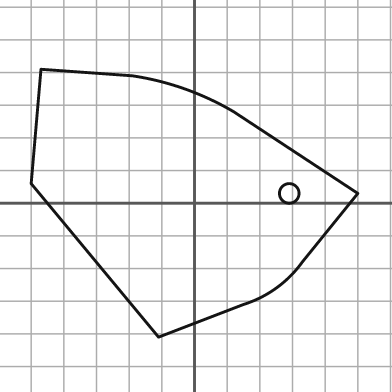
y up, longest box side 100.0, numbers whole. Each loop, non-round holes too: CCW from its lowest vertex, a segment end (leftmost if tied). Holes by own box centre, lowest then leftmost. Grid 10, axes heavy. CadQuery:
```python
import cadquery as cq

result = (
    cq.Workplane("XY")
    .moveTo(-11.0, -41.0)
    .lineTo(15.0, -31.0)
    .threePointArc((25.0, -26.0), (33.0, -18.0))
    .lineTo(50.0, 3.0)
    .lineTo(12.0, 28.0)
    .threePointArc((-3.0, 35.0), (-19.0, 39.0))
    .lineTo(-47.0, 41.0)
    .lineTo(-50.0, 6.0)
    .close()
    .moveTo(29.0, 3.0)
    .circle(3.0)
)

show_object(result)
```